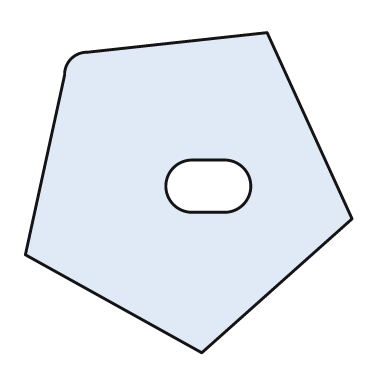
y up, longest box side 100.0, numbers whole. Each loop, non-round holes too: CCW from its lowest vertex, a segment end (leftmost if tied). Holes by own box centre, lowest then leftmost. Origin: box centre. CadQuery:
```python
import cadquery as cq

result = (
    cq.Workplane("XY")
    .moveTo(4.0, -49.0)
    .lineTo(50.0, -8.0)
    .lineTo(24.0, 49.0)
    .lineTo(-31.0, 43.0)
    .threePointArc((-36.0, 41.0), (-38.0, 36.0))
    .lineTo(-50.0, -19.0)
    .close()
    .moveTo(1.0, -6.0)
    .lineTo(11.0, -6.0)
    .threePointArc((19.0, 2.0), (11.0, 10.0))
    .lineTo(1.0, 10.0)
    .threePointArc((-7.0, 2.0), (1.0, -6.0))
    .close()
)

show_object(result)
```